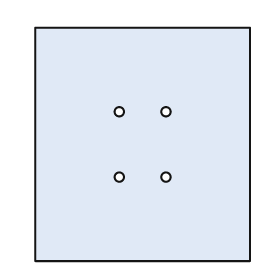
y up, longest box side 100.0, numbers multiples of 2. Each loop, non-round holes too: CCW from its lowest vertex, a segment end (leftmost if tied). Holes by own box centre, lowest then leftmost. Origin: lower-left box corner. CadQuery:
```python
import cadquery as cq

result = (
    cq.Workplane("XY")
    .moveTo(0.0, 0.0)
    .lineTo(92.0, 0.0)
    .lineTo(92.0, 100.0)
    .lineTo(0.0, 100.0)
    .close()
    .moveTo(36.0, 36.0)
    .circle(2.0)
    .moveTo(56.0, 36.0)
    .circle(2.0)
    .moveTo(36.0, 64.0)
    .circle(2.0)
    .moveTo(56.0, 64.0)
    .circle(2.0)
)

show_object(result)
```